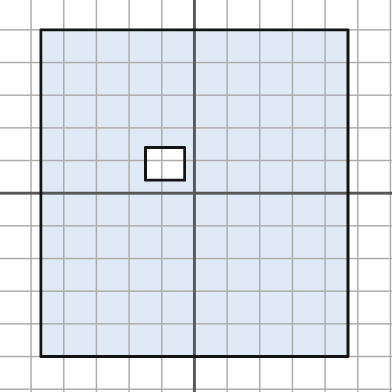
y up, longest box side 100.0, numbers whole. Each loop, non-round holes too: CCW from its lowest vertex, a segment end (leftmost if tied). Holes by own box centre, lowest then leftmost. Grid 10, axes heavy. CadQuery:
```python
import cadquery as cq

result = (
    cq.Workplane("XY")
    .moveTo(-47.0, -50.0)
    .lineTo(47.0, -50.0)
    .lineTo(47.0, 50.0)
    .lineTo(-47.0, 50.0)
    .close()
    .moveTo(-15.0, 4.0)
    .lineTo(-3.0, 4.0)
    .lineTo(-3.0, 14.0)
    .lineTo(-15.0, 14.0)
    .close()
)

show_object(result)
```